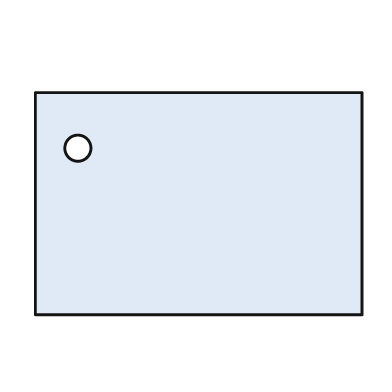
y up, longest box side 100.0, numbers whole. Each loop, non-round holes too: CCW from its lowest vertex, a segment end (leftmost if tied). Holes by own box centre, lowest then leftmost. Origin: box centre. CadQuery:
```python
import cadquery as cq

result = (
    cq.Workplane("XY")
    .moveTo(-50.0, -34.0)
    .lineTo(50.0, -34.0)
    .lineTo(50.0, 34.0)
    .lineTo(-50.0, 34.0)
    .close()
    .moveTo(-37.0, 17.0)
    .circle(4.0)
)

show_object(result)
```